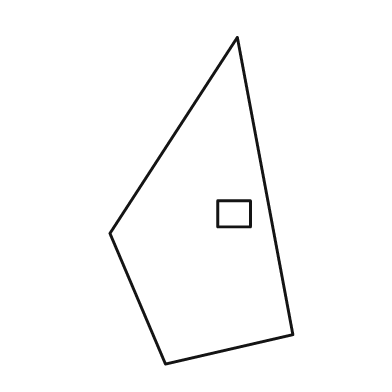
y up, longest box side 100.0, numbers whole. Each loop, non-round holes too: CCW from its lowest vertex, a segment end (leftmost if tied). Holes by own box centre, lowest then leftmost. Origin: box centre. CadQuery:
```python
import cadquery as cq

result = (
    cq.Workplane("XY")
    .moveTo(-11.0, -50.0)
    .lineTo(28.0, -41.0)
    .lineTo(11.0, 50.0)
    .lineTo(-28.0, -10.0)
    .close()
    .moveTo(5.0, -8.0)
    .lineTo(15.0, -8.0)
    .lineTo(15.0, 0.0)
    .lineTo(5.0, 0.0)
    .close()
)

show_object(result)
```